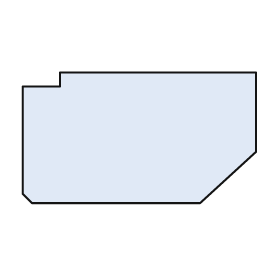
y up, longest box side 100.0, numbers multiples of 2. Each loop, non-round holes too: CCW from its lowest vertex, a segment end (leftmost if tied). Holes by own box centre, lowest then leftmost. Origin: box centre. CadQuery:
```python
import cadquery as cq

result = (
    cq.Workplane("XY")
    .moveTo(-46.0, -28.0)
    .lineTo(26.0, -28.0)
    .lineTo(50.0, -6.0)
    .lineTo(50.0, 28.0)
    .lineTo(-34.0, 28.0)
    .lineTo(-34.0, 22.0)
    .lineTo(-50.0, 22.0)
    .lineTo(-50.0, -24.0)
    .close()
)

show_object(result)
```